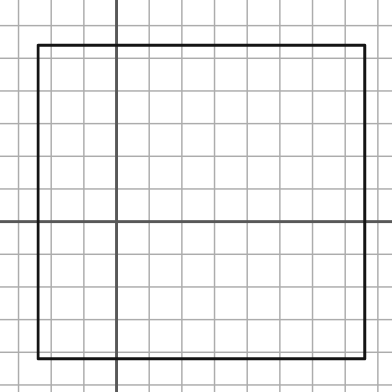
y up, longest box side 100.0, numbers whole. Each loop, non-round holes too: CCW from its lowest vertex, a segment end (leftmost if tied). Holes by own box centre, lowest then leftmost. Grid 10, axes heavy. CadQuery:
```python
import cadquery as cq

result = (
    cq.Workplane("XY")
    .moveTo(-24.0, -42.0)
    .lineTo(76.0, -42.0)
    .lineTo(76.0, 54.0)
    .lineTo(-24.0, 54.0)
    .close()
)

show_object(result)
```